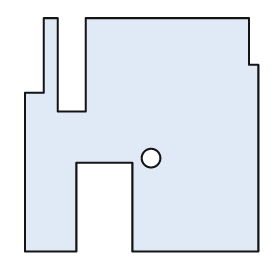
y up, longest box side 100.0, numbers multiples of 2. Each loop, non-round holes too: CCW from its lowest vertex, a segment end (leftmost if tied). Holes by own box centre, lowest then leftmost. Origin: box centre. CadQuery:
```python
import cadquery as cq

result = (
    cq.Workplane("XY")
    .moveTo(-50.0, -50.0)
    .lineTo(-28.0, -50.0)
    .lineTo(-28.0, -12.0)
    .lineTo(-4.0, -12.0)
    .lineTo(-4.0, -50.0)
    .lineTo(50.0, -50.0)
    .lineTo(50.0, 30.0)
    .lineTo(46.0, 30.0)
    .lineTo(46.0, 50.0)
    .lineTo(-24.0, 50.0)
    .lineTo(-24.0, 10.0)
    .lineTo(-36.0, 10.0)
    .lineTo(-36.0, 50.0)
    .lineTo(-42.0, 50.0)
    .lineTo(-42.0, 18.0)
    .lineTo(-50.0, 18.0)
    .close()
    .moveTo(4.0, -10.0)
    .circle(4.0)
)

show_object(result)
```